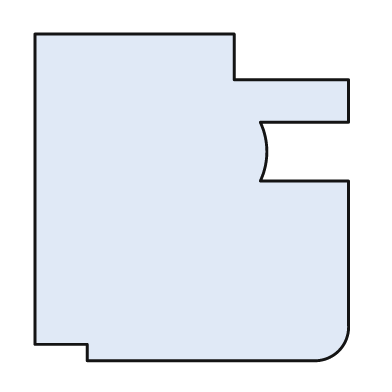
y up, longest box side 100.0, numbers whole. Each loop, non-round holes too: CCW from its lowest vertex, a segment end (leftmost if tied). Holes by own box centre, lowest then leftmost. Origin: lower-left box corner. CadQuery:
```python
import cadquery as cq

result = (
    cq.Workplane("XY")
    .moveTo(16.0, 0.0)
    .lineTo(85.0, 0.0)
    .threePointArc((93.0, 3.0), (96.0, 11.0))
    .lineTo(96.0, 55.0)
    .lineTo(69.0, 55.0)
    .threePointArc((71.0, 64.0), (69.0, 73.0))
    .lineTo(96.0, 73.0)
    .lineTo(96.0, 86.0)
    .lineTo(61.0, 86.0)
    .lineTo(61.0, 100.0)
    .lineTo(0.0, 100.0)
    .lineTo(0.0, 5.0)
    .lineTo(16.0, 5.0)
    .close()
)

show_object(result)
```